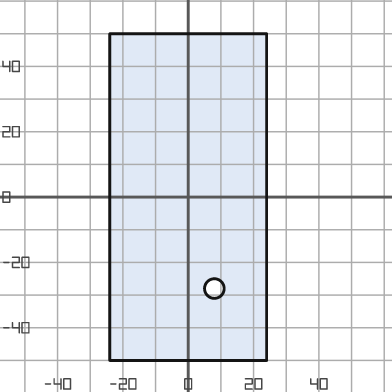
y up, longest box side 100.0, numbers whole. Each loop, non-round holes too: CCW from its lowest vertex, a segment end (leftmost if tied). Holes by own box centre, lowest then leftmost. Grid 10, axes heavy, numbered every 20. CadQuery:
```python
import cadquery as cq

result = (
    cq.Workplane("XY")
    .moveTo(-24.0, -50.0)
    .lineTo(24.0, -50.0)
    .lineTo(24.0, 50.0)
    .lineTo(-24.0, 50.0)
    .close()
    .moveTo(8.0, -28.0)
    .circle(3.0)
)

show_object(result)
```